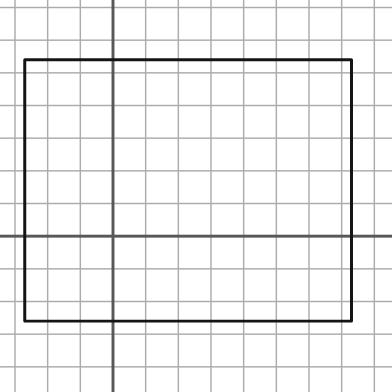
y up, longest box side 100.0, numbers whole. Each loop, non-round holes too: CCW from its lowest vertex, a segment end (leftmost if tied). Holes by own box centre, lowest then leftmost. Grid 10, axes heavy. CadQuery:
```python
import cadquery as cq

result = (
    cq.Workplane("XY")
    .moveTo(-27.0, -26.0)
    .lineTo(73.0, -26.0)
    .lineTo(73.0, 54.0)
    .lineTo(-27.0, 54.0)
    .close()
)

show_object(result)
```